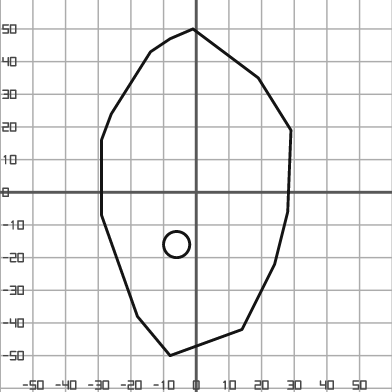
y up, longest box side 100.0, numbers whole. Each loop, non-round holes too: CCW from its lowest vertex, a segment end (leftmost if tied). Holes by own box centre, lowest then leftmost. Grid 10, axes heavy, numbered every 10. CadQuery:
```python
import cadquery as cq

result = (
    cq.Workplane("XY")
    .moveTo(-8.0, -50.0)
    .lineTo(14.0, -42.0)
    .lineTo(24.0, -22.0)
    .lineTo(28.0, -6.0)
    .lineTo(29.0, 19.0)
    .lineTo(19.0, 35.0)
    .lineTo(-1.0, 50.0)
    .lineTo(-8.0, 47.0)
    .lineTo(-14.0, 43.0)
    .lineTo(-26.0, 24.0)
    .lineTo(-29.0, 16.0)
    .lineTo(-29.0, -7.0)
    .lineTo(-18.0, -38.0)
    .close()
    .moveTo(-6.0, -16.0)
    .circle(4.0)
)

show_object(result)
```